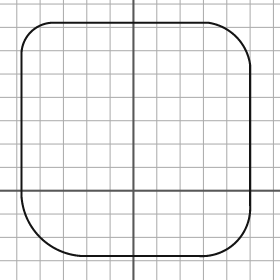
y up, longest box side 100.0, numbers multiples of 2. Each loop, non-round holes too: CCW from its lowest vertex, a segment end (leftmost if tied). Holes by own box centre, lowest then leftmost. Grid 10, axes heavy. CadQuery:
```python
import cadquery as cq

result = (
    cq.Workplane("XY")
    .moveTo(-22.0, -28.0)
    .lineTo(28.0, -28.0)
    .threePointArc((44.0, -22.0), (50.0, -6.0))
    .lineTo(50.0, 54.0)
    .threePointArc((44.0, 66.0), (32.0, 72.0))
    .lineTo(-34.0, 72.0)
    .threePointArc((-44.0, 68.0), (-48.0, 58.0))
    .lineTo(-48.0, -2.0)
    .threePointArc((-40.0, -20.0), (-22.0, -28.0))
    .close()
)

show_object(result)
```